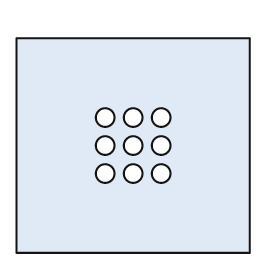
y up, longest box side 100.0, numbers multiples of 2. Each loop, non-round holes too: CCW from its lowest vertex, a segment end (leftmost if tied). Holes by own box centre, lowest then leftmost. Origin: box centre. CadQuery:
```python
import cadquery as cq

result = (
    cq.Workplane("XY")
    .moveTo(-50.0, -46.0)
    .lineTo(50.0, -46.0)
    .lineTo(50.0, 46.0)
    .lineTo(-50.0, 46.0)
    .close()
    .moveTo(-12.0, -12.0)
    .circle(4.0)
    .moveTo(0.0, -12.0)
    .circle(4.0)
    .moveTo(12.0, -12.0)
    .circle(4.0)
    .moveTo(-12.0, 0.0)
    .circle(4.0)
    .moveTo(0.0, 0.0)
    .circle(4.0)
    .moveTo(12.0, 0.0)
    .circle(4.0)
    .moveTo(-12.0, 12.0)
    .circle(4.0)
    .moveTo(0.0, 12.0)
    .circle(4.0)
    .moveTo(12.0, 12.0)
    .circle(4.0)
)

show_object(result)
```